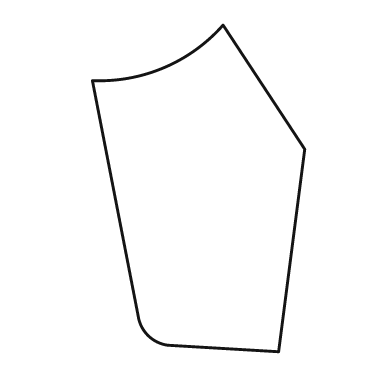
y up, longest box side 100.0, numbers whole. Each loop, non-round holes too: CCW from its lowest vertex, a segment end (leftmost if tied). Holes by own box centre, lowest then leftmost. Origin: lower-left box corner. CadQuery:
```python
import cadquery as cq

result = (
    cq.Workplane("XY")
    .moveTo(57.0, 0.0)
    .lineTo(65.0, 62.0)
    .lineTo(40.0, 100.0)
    .threePointArc((22.0, 87.0), (0.0, 83.0))
    .lineTo(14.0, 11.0)
    .threePointArc((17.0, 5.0), (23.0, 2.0))
    .close()
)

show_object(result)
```